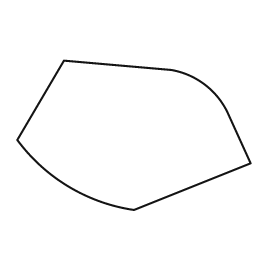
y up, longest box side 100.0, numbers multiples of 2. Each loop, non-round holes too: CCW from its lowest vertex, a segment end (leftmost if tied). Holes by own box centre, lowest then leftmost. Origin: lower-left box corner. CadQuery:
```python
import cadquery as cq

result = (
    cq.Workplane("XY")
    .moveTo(50.0, 0.0)
    .lineTo(100.0, 20.0)
    .lineTo(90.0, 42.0)
    .threePointArc((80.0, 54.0), (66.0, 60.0))
    .lineTo(20.0, 64.0)
    .lineTo(0.0, 30.0)
    .threePointArc((22.0, 10.0), (50.0, 0.0))
    .close()
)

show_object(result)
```